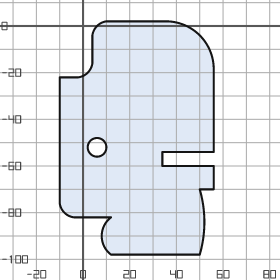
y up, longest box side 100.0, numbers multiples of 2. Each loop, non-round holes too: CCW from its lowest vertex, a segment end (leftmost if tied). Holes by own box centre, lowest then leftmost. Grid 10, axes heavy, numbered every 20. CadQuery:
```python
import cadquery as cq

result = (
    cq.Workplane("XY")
    .moveTo(12.0, -98.0)
    .lineTo(50.0, -98.0)
    .threePointArc((52.0, -84.0), (50.0, -70.0))
    .lineTo(56.0, -70.0)
    .lineTo(56.0, -60.0)
    .lineTo(34.0, -60.0)
    .lineTo(34.0, -54.0)
    .lineTo(56.0, -54.0)
    .lineTo(56.0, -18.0)
    .threePointArc((50.0, -4.0), (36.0, 2.0))
    .lineTo(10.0, 2.0)
    .threePointArc((6.0, 0.0), (4.0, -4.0))
    .lineTo(4.0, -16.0)
    .threePointArc((2.0, -20.0), (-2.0, -22.0))
    .lineTo(-10.0, -22.0)
    .lineTo(-10.0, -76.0)
    .threePointArc((-8.0, -80.0), (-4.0, -82.0))
    .lineTo(12.0, -82.0)
    .threePointArc((8.0, -90.0), (12.0, -98.0))
    .close()
    .moveTo(6.0, -52.0)
    .circle(4.0)
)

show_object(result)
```